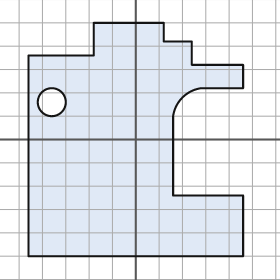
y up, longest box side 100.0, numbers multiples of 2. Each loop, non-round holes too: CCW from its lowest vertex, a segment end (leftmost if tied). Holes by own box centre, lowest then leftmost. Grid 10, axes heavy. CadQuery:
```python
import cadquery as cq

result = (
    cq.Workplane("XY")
    .moveTo(-46.0, -50.0)
    .lineTo(46.0, -50.0)
    .lineTo(46.0, -24.0)
    .lineTo(16.0, -24.0)
    .lineTo(16.0, 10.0)
    .threePointArc((20.0, 18.0), (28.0, 22.0))
    .lineTo(46.0, 22.0)
    .lineTo(46.0, 32.0)
    .lineTo(24.0, 32.0)
    .lineTo(24.0, 42.0)
    .lineTo(12.0, 42.0)
    .lineTo(12.0, 50.0)
    .lineTo(-18.0, 50.0)
    .lineTo(-18.0, 36.0)
    .lineTo(-46.0, 36.0)
    .close()
    .moveTo(-36.0, 16.0)
    .circle(6.0)
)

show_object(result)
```